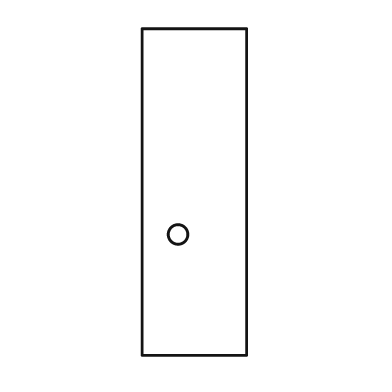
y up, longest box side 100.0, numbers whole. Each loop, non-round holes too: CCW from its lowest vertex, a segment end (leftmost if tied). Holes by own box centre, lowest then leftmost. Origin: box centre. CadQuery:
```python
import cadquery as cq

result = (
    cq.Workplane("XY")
    .moveTo(-16.0, -50.0)
    .lineTo(16.0, -50.0)
    .lineTo(16.0, 50.0)
    .lineTo(-16.0, 50.0)
    .close()
    .moveTo(-5.0, -13.0)
    .circle(3.0)
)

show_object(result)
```